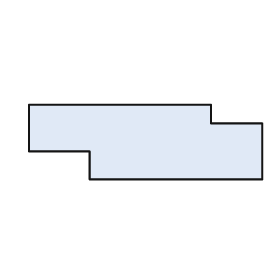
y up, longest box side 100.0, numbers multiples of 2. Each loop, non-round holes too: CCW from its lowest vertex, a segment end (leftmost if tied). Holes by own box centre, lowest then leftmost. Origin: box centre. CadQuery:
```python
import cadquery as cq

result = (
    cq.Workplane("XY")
    .moveTo(-24.0, -16.0)
    .lineTo(50.0, -16.0)
    .lineTo(50.0, 8.0)
    .lineTo(28.0, 8.0)
    .lineTo(28.0, 16.0)
    .lineTo(-50.0, 16.0)
    .lineTo(-50.0, -4.0)
    .lineTo(-24.0, -4.0)
    .close()
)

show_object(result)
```